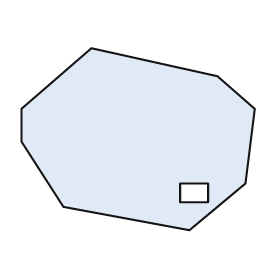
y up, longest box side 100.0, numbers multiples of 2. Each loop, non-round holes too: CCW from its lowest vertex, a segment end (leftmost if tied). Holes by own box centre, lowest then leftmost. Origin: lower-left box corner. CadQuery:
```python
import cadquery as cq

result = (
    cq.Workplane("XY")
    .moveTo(72.0, 0.0)
    .lineTo(96.0, 20.0)
    .lineTo(100.0, 52.0)
    .lineTo(84.0, 66.0)
    .lineTo(30.0, 78.0)
    .lineTo(0.0, 52.0)
    .lineTo(0.0, 38.0)
    .lineTo(18.0, 10.0)
    .close()
    .moveTo(68.0, 12.0)
    .lineTo(80.0, 12.0)
    .lineTo(80.0, 20.0)
    .lineTo(68.0, 20.0)
    .close()
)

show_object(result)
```